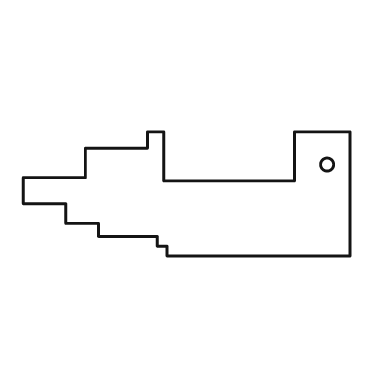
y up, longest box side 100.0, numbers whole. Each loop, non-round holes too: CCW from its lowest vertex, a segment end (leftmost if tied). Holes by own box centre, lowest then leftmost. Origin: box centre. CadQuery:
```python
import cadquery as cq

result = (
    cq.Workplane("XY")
    .moveTo(-6.0, -19.0)
    .lineTo(50.0, -19.0)
    .lineTo(50.0, 19.0)
    .lineTo(33.0, 19.0)
    .lineTo(33.0, 4.0)
    .lineTo(-7.0, 4.0)
    .lineTo(-7.0, 19.0)
    .lineTo(-12.0, 19.0)
    .lineTo(-12.0, 14.0)
    .lineTo(-31.0, 14.0)
    .lineTo(-31.0, 5.0)
    .lineTo(-50.0, 5.0)
    .lineTo(-50.0, -3.0)
    .lineTo(-37.0, -3.0)
    .lineTo(-37.0, -9.0)
    .lineTo(-27.0, -9.0)
    .lineTo(-27.0, -13.0)
    .lineTo(-9.0, -13.0)
    .lineTo(-9.0, -16.0)
    .lineTo(-6.0, -16.0)
    .close()
    .moveTo(43.0, 9.0)
    .circle(2.0)
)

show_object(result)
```